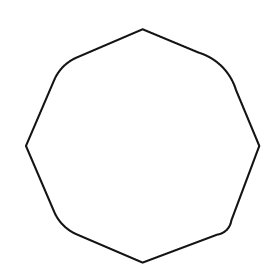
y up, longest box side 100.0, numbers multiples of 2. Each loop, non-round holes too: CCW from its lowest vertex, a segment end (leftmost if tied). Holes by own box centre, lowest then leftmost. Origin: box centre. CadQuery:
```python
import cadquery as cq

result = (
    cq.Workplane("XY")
    .moveTo(0.0, -50.0)
    .lineTo(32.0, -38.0)
    .threePointArc((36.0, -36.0), (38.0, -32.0))
    .lineTo(50.0, 0.0)
    .lineTo(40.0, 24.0)
    .threePointArc((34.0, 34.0), (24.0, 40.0))
    .lineTo(0.0, 50.0)
    .lineTo(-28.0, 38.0)
    .threePointArc((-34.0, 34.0), (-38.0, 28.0))
    .lineTo(-50.0, 0.0)
    .lineTo(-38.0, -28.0)
    .threePointArc((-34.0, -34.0), (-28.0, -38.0))
    .close()
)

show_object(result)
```